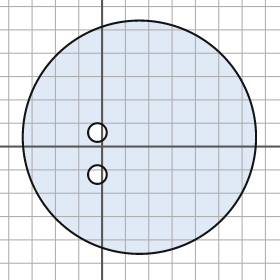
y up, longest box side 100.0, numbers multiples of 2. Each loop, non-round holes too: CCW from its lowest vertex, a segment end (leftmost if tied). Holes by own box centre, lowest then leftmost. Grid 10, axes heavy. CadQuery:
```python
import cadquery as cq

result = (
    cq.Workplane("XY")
    .moveTo(16.0, 4.0)
    .circle(50.0)
    .moveTo(-2.0, -12.0)
    .circle(4.0)
    .moveTo(-2.0, 6.0)
    .circle(4.0)
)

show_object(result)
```